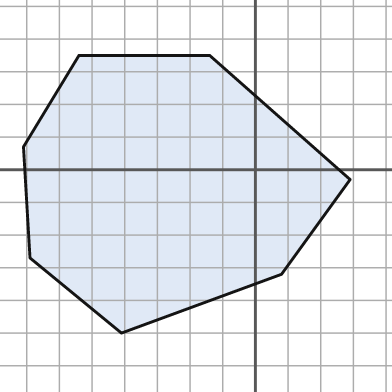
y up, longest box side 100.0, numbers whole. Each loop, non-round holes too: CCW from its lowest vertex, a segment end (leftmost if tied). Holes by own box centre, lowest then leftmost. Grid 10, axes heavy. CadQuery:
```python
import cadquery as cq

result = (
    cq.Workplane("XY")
    .moveTo(-41.0, -50.0)
    .lineTo(8.0, -32.0)
    .lineTo(29.0, -3.0)
    .lineTo(-14.0, 35.0)
    .lineTo(-54.0, 35.0)
    .lineTo(-71.0, 7.0)
    .lineTo(-69.0, -27.0)
    .close()
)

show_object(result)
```